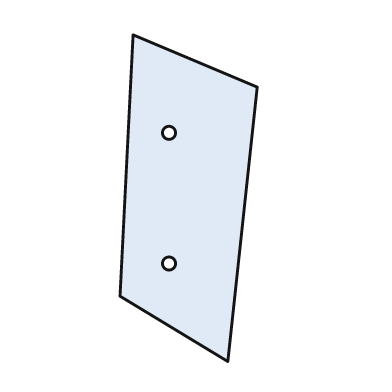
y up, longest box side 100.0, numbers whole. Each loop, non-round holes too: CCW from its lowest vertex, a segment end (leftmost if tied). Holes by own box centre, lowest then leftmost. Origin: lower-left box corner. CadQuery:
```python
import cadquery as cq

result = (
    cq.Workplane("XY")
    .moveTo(33.0, 0.0)
    .lineTo(42.0, 84.0)
    .lineTo(4.0, 100.0)
    .lineTo(0.0, 20.0)
    .close()
    .moveTo(15.0, 30.0)
    .circle(2.0)
    .moveTo(15.0, 70.0)
    .circle(2.0)
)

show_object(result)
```